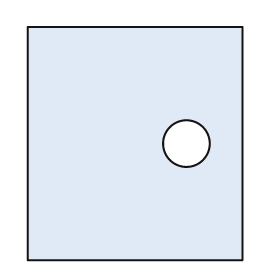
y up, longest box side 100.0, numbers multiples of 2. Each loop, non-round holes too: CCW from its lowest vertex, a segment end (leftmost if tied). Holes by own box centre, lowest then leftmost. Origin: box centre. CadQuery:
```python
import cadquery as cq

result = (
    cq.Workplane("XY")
    .moveTo(-46.0, -50.0)
    .lineTo(46.0, -50.0)
    .lineTo(46.0, 50.0)
    .lineTo(-46.0, 50.0)
    .close()
    .moveTo(22.0, 0.0)
    .circle(10.0)
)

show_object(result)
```